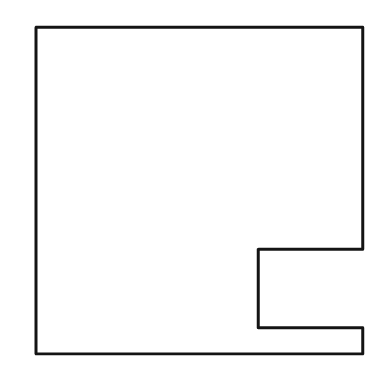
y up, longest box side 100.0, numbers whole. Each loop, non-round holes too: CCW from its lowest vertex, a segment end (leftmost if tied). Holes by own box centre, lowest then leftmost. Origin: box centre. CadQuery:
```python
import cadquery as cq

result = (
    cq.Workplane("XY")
    .moveTo(-50.0, -50.0)
    .lineTo(50.0, -50.0)
    .lineTo(50.0, -42.0)
    .lineTo(18.0, -42.0)
    .lineTo(18.0, -18.0)
    .lineTo(50.0, -18.0)
    .lineTo(50.0, 50.0)
    .lineTo(-50.0, 50.0)
    .close()
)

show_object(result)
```